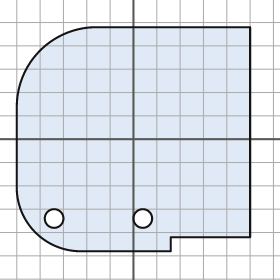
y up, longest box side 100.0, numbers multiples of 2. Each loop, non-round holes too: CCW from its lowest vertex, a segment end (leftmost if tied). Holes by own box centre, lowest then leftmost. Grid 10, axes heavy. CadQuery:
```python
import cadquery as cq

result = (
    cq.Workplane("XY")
    .moveTo(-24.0, -48.0)
    .lineTo(16.0, -48.0)
    .lineTo(16.0, -42.0)
    .lineTo(50.0, -42.0)
    .lineTo(50.0, 48.0)
    .lineTo(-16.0, 48.0)
    .threePointArc((-40.0, 38.0), (-50.0, 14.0))
    .lineTo(-50.0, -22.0)
    .threePointArc((-42.0, -40.0), (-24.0, -48.0))
    .close()
    .moveTo(-34.0, -34.0)
    .circle(4.0)
    .moveTo(4.0, -34.0)
    .circle(4.0)
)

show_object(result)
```